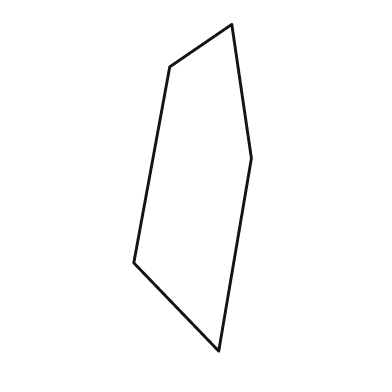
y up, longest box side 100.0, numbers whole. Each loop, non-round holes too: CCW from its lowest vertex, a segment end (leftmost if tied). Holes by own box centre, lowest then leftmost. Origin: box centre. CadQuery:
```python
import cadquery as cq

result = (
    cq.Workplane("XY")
    .moveTo(8.0, -50.0)
    .lineTo(18.0, 9.0)
    .lineTo(12.0, 50.0)
    .lineTo(-7.0, 37.0)
    .lineTo(-18.0, -23.0)
    .close()
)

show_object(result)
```